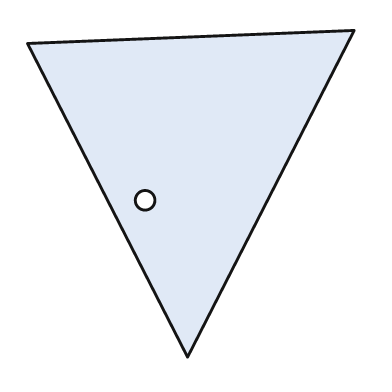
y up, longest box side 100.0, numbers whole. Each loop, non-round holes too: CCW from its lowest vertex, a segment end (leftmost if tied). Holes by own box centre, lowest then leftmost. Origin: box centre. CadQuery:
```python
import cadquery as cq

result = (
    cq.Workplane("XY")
    .moveTo(-1.0, -50.0)
    .lineTo(50.0, 50.0)
    .lineTo(-50.0, 46.0)
    .close()
    .moveTo(-14.0, -2.0)
    .circle(3.0)
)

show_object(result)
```